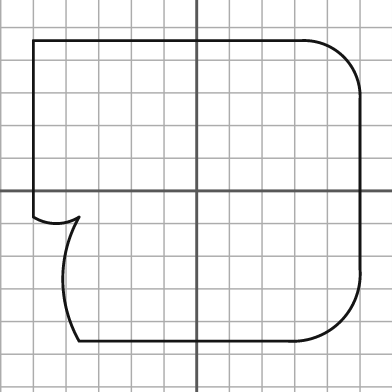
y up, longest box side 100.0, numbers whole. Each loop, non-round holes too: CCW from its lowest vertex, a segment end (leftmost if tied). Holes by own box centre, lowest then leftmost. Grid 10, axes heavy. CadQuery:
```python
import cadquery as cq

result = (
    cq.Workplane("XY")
    .moveTo(-36.0, -46.0)
    .lineTo(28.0, -46.0)
    .threePointArc((44.0, -40.0), (50.0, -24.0))
    .lineTo(50.0, 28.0)
    .threePointArc((45.0, 41.0), (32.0, 46.0))
    .lineTo(-50.0, 46.0)
    .lineTo(-50.0, -8.0)
    .threePointArc((-43.0, -10.0), (-36.0, -8.0))
    .threePointArc((-41.0, -27.0), (-36.0, -46.0))
    .close()
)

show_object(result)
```